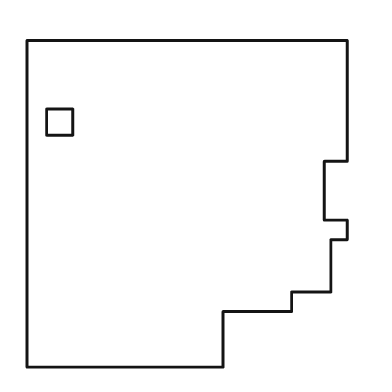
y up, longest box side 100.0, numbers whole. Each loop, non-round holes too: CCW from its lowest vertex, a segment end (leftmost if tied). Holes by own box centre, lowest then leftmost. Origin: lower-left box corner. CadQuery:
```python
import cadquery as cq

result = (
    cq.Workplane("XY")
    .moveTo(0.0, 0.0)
    .lineTo(60.0, 0.0)
    .lineTo(60.0, 17.0)
    .lineTo(81.0, 17.0)
    .lineTo(81.0, 23.0)
    .lineTo(93.0, 23.0)
    .lineTo(93.0, 39.0)
    .lineTo(98.0, 39.0)
    .lineTo(98.0, 45.0)
    .lineTo(91.0, 45.0)
    .lineTo(91.0, 63.0)
    .lineTo(98.0, 63.0)
    .lineTo(98.0, 100.0)
    .lineTo(0.0, 100.0)
    .close()
    .moveTo(6.0, 71.0)
    .lineTo(14.0, 71.0)
    .lineTo(14.0, 79.0)
    .lineTo(6.0, 79.0)
    .close()
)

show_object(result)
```